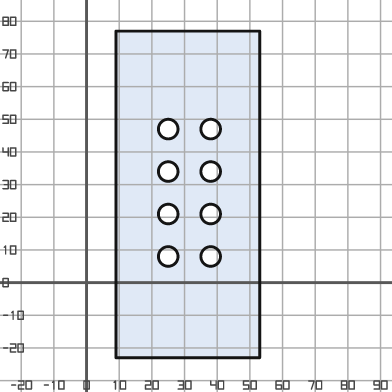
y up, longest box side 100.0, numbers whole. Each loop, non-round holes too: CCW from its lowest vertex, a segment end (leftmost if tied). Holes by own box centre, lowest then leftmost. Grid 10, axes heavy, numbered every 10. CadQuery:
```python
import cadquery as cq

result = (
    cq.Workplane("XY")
    .moveTo(9.0, -23.0)
    .lineTo(53.0, -23.0)
    .lineTo(53.0, 77.0)
    .lineTo(9.0, 77.0)
    .close()
    .moveTo(25.0, 8.0)
    .circle(3.0)
    .moveTo(38.0, 8.0)
    .circle(3.0)
    .moveTo(25.0, 21.0)
    .circle(3.0)
    .moveTo(38.0, 21.0)
    .circle(3.0)
    .moveTo(25.0, 34.0)
    .circle(3.0)
    .moveTo(38.0, 34.0)
    .circle(3.0)
    .moveTo(25.0, 47.0)
    .circle(3.0)
    .moveTo(38.0, 47.0)
    .circle(3.0)
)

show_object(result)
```